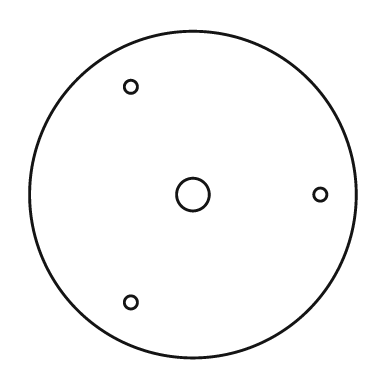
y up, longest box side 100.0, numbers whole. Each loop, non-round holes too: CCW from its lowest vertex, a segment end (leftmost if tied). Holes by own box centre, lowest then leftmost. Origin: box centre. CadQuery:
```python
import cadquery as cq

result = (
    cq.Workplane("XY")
    .moveTo(0.0, 0.0)
    .circle(50.0)
    .moveTo(-19.0, -33.0)
    .circle(2.0)
    .moveTo(0.0, 0.0)
    .circle(5.0)
    .moveTo(39.0, 0.0)
    .circle(2.0)
    .moveTo(-19.0, 33.0)
    .circle(2.0)
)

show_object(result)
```